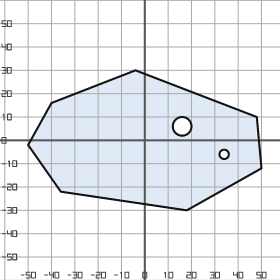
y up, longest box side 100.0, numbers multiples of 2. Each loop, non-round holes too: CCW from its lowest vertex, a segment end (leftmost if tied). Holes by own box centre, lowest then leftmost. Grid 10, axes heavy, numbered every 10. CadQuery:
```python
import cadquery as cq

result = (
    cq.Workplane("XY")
    .moveTo(18.0, -30.0)
    .lineTo(50.0, -12.0)
    .lineTo(48.0, 10.0)
    .lineTo(-4.0, 30.0)
    .lineTo(-40.0, 16.0)
    .lineTo(-50.0, -2.0)
    .lineTo(-36.0, -22.0)
    .close()
    .moveTo(34.0, -6.0)
    .circle(2.0)
    .moveTo(16.0, 6.0)
    .circle(4.0)
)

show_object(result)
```